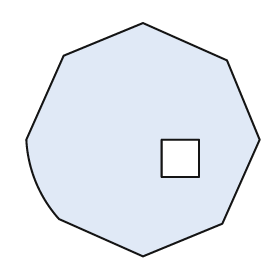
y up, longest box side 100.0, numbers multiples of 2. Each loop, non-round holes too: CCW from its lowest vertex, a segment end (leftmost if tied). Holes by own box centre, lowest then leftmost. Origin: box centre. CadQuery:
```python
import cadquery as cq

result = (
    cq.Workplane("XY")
    .moveTo(0.0, -50.0)
    .lineTo(34.0, -36.0)
    .lineTo(50.0, 0.0)
    .lineTo(36.0, 34.0)
    .lineTo(0.0, 50.0)
    .lineTo(-34.0, 36.0)
    .lineTo(-50.0, 0.0)
    .threePointArc((-46.0, -18.0), (-36.0, -34.0))
    .close()
    .moveTo(8.0, -16.0)
    .lineTo(24.0, -16.0)
    .lineTo(24.0, 0.0)
    .lineTo(8.0, 0.0)
    .close()
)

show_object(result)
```